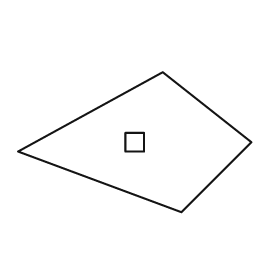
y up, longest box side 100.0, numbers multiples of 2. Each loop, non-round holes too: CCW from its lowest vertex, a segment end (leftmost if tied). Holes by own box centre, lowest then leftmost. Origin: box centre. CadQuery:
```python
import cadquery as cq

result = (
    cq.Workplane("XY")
    .moveTo(20.0, -30.0)
    .lineTo(50.0, 0.0)
    .lineTo(12.0, 30.0)
    .lineTo(-50.0, -4.0)
    .close()
    .moveTo(-4.0, -4.0)
    .lineTo(4.0, -4.0)
    .lineTo(4.0, 4.0)
    .lineTo(-4.0, 4.0)
    .close()
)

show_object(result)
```